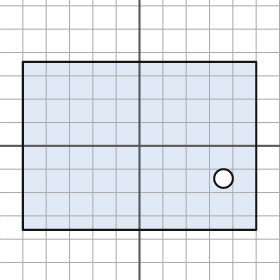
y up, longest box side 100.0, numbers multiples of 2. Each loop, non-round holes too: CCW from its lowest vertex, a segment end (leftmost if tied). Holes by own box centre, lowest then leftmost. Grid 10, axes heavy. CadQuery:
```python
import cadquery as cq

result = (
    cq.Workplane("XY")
    .moveTo(-50.0, -36.0)
    .lineTo(50.0, -36.0)
    .lineTo(50.0, 36.0)
    .lineTo(-50.0, 36.0)
    .close()
    .moveTo(36.0, -14.0)
    .circle(4.0)
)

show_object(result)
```